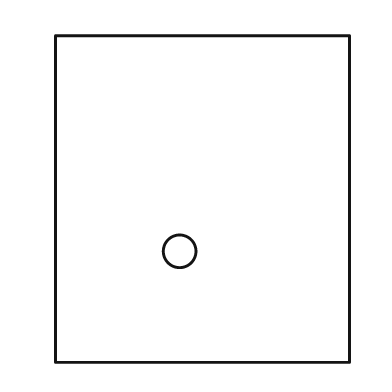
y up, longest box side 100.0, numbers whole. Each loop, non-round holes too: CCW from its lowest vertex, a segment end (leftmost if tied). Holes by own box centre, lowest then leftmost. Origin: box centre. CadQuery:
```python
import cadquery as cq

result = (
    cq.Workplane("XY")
    .moveTo(-45.0, -50.0)
    .lineTo(45.0, -50.0)
    .lineTo(45.0, 50.0)
    .lineTo(-45.0, 50.0)
    .close()
    .moveTo(-7.0, -16.0)
    .circle(5.0)
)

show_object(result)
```